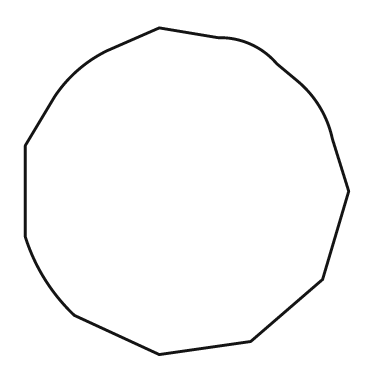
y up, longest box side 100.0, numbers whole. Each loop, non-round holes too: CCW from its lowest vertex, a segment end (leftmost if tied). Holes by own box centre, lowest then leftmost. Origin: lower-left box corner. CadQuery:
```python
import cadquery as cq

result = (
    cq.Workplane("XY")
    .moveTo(41.0, 0.0)
    .lineTo(69.0, 4.0)
    .lineTo(91.0, 23.0)
    .lineTo(99.0, 50.0)
    .lineTo(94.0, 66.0)
    .threePointArc((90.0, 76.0), (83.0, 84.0))
    .lineTo(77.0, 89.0)
    .threePointArc((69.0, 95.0), (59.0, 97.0))
    .lineTo(41.0, 100.0)
    .lineTo(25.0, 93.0)
    .threePointArc((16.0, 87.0), (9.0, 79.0))
    .lineTo(0.0, 64.0)
    .lineTo(0.0, 36.0)
    .threePointArc((6.0, 23.0), (15.0, 12.0))
    .close()
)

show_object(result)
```